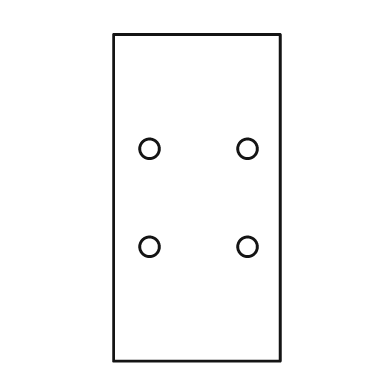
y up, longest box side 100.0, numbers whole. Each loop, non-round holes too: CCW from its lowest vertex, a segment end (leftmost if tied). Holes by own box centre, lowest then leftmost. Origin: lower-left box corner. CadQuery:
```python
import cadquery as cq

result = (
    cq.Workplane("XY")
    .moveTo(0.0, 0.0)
    .lineTo(51.0, 0.0)
    .lineTo(51.0, 100.0)
    .lineTo(0.0, 100.0)
    .close()
    .moveTo(11.0, 35.0)
    .circle(3.0)
    .moveTo(41.0, 35.0)
    .circle(3.0)
    .moveTo(11.0, 65.0)
    .circle(3.0)
    .moveTo(41.0, 65.0)
    .circle(3.0)
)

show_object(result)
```